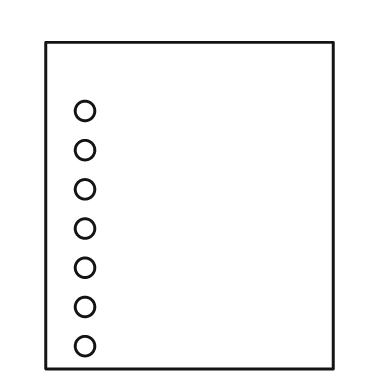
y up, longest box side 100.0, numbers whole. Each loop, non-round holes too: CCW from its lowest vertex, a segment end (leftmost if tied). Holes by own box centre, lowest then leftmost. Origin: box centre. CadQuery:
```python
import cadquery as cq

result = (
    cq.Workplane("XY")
    .moveTo(-44.0, -50.0)
    .lineTo(44.0, -50.0)
    .lineTo(44.0, 50.0)
    .lineTo(-44.0, 50.0)
    .close()
    .moveTo(-32.0, -43.0)
    .circle(3.0)
    .moveTo(-32.0, -31.0)
    .circle(3.0)
    .moveTo(-32.0, -19.0)
    .circle(3.0)
    .moveTo(-32.0, -7.0)
    .circle(3.0)
    .moveTo(-32.0, 5.0)
    .circle(3.0)
    .moveTo(-32.0, 17.0)
    .circle(3.0)
    .moveTo(-32.0, 29.0)
    .circle(3.0)
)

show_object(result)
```